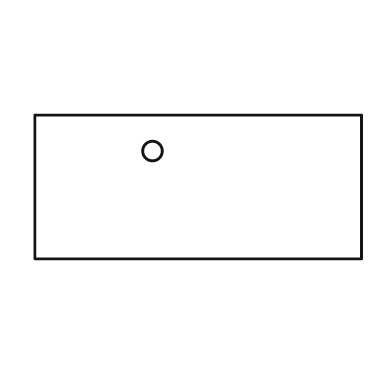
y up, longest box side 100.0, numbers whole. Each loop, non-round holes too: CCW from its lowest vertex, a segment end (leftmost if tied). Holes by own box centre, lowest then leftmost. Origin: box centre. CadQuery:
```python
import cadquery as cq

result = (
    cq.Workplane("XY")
    .moveTo(-50.0, -22.0)
    .lineTo(50.0, -22.0)
    .lineTo(50.0, 22.0)
    .lineTo(-50.0, 22.0)
    .close()
    .moveTo(-14.0, 11.0)
    .circle(3.0)
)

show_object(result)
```